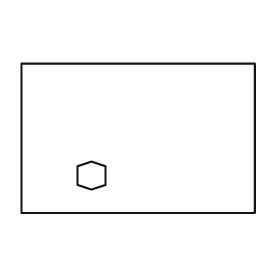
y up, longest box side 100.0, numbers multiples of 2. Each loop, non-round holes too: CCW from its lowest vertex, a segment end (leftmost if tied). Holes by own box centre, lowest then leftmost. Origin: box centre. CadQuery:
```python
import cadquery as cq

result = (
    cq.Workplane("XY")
    .moveTo(-50.0, -32.0)
    .lineTo(50.0, -32.0)
    .lineTo(50.0, 32.0)
    .lineTo(-50.0, 32.0)
    .close()
    .moveTo(-20.0, -22.0)
    .lineTo(-14.0, -20.0)
    .lineTo(-14.0, -12.0)
    .lineTo(-20.0, -10.0)
    .lineTo(-26.0, -12.0)
    .lineTo(-26.0, -20.0)
    .close()
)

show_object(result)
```